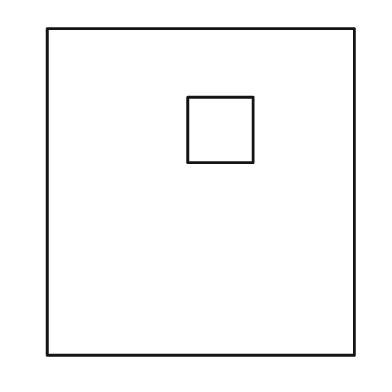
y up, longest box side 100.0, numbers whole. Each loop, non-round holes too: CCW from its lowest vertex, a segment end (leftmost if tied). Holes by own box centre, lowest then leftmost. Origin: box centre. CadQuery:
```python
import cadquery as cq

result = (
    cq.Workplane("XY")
    .moveTo(-47.0, -50.0)
    .lineTo(47.0, -50.0)
    .lineTo(47.0, 50.0)
    .lineTo(-47.0, 50.0)
    .close()
    .moveTo(-4.0, 9.0)
    .lineTo(16.0, 9.0)
    .lineTo(16.0, 29.0)
    .lineTo(-4.0, 29.0)
    .close()
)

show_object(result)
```